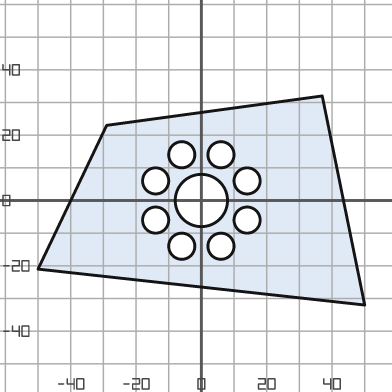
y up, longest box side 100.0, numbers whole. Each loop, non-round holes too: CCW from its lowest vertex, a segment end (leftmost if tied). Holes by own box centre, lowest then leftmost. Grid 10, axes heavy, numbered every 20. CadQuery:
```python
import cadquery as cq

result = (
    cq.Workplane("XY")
    .moveTo(50.0, -32.0)
    .lineTo(37.0, 32.0)
    .lineTo(-29.0, 23.0)
    .lineTo(-50.0, -21.0)
    .close()
    .moveTo(-6.0, -14.0)
    .circle(4.0)
    .moveTo(6.0, -14.0)
    .circle(4.0)
    .moveTo(-14.0, -6.0)
    .circle(4.0)
    .moveTo(14.0, -6.0)
    .circle(4.0)
    .moveTo(0.0, 0.0)
    .circle(8.0)
    .moveTo(-14.0, 6.0)
    .circle(4.0)
    .moveTo(14.0, 6.0)
    .circle(4.0)
    .moveTo(-6.0, 14.0)
    .circle(4.0)
    .moveTo(6.0, 14.0)
    .circle(4.0)
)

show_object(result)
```